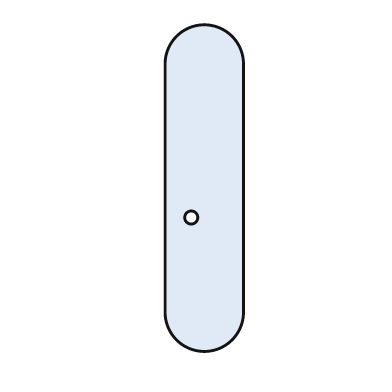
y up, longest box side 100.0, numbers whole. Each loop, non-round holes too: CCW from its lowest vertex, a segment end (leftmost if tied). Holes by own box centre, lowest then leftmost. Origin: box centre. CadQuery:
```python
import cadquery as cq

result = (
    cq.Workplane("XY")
    .moveTo(-12.0, -38.0)
    .threePointArc((0.0, -50.0), (12.0, -38.0))
    .lineTo(12.0, 38.0)
    .threePointArc((0.0, 50.0), (-12.0, 38.0))
    .close()
    .moveTo(-4.0, -9.0)
    .circle(2.0)
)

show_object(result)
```